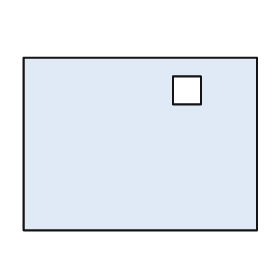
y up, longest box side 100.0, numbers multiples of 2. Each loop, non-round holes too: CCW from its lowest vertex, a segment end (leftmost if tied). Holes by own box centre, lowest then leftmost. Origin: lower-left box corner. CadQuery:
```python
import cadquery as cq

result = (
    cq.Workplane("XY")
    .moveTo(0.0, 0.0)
    .lineTo(100.0, 0.0)
    .lineTo(100.0, 74.0)
    .lineTo(0.0, 74.0)
    .close()
    .moveTo(64.0, 54.0)
    .lineTo(76.0, 54.0)
    .lineTo(76.0, 66.0)
    .lineTo(64.0, 66.0)
    .close()
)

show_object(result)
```